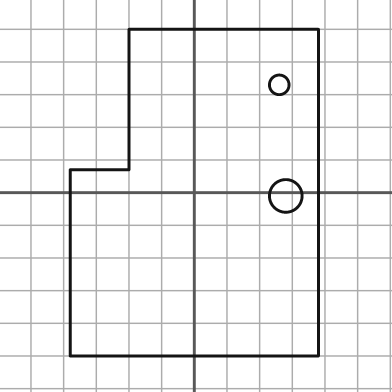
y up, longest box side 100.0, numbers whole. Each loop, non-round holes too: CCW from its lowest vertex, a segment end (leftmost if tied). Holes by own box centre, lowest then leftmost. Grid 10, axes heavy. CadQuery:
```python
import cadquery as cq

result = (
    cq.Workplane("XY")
    .moveTo(-38.0, -50.0)
    .lineTo(38.0, -50.0)
    .lineTo(38.0, 50.0)
    .lineTo(-20.0, 50.0)
    .lineTo(-20.0, 7.0)
    .lineTo(-38.0, 7.0)
    .close()
    .moveTo(28.0, -1.0)
    .circle(5.0)
    .moveTo(26.0, 33.0)
    .circle(3.0)
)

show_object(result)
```